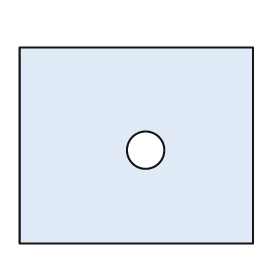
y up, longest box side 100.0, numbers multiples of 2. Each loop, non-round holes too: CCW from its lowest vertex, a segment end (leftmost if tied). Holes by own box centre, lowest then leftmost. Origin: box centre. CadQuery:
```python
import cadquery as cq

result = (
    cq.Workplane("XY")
    .moveTo(-50.0, -42.0)
    .lineTo(50.0, -42.0)
    .lineTo(50.0, 42.0)
    .lineTo(-50.0, 42.0)
    .close()
    .moveTo(4.0, -2.0)
    .circle(8.0)
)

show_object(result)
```